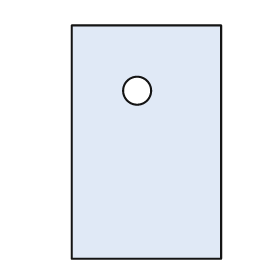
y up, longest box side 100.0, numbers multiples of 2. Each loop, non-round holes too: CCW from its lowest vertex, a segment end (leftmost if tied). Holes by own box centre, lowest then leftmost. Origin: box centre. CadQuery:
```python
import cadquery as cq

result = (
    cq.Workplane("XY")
    .moveTo(-32.0, -50.0)
    .lineTo(32.0, -50.0)
    .lineTo(32.0, 50.0)
    .lineTo(-32.0, 50.0)
    .close()
    .moveTo(-4.0, 22.0)
    .circle(6.0)
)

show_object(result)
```